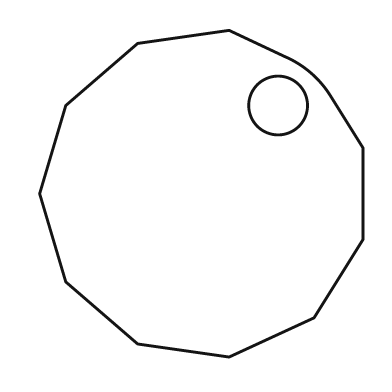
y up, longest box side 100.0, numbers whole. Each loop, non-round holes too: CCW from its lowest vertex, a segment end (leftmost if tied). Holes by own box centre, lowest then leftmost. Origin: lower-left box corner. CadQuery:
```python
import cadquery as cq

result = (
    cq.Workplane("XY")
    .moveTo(58.0, 0.0)
    .lineTo(84.0, 12.0)
    .lineTo(99.0, 36.0)
    .lineTo(99.0, 64.0)
    .lineTo(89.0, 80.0)
    .threePointArc((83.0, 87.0), (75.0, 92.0))
    .lineTo(58.0, 100.0)
    .lineTo(30.0, 96.0)
    .lineTo(8.0, 77.0)
    .lineTo(0.0, 50.0)
    .lineTo(8.0, 23.0)
    .lineTo(30.0, 4.0)
    .close()
    .moveTo(73.0, 77.0)
    .circle(9.0)
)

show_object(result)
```